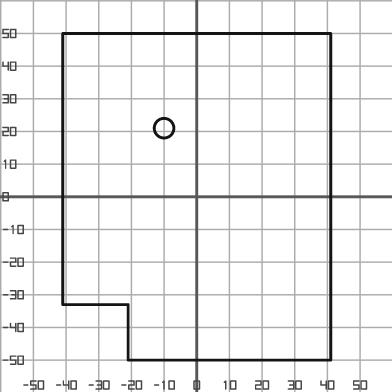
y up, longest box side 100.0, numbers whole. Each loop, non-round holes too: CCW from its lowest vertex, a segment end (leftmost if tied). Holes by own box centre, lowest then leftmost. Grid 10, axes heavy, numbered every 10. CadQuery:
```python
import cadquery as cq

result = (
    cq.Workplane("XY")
    .moveTo(-21.0, -50.0)
    .lineTo(41.0, -50.0)
    .lineTo(41.0, 50.0)
    .lineTo(-41.0, 50.0)
    .lineTo(-41.0, -33.0)
    .lineTo(-21.0, -33.0)
    .close()
    .moveTo(-10.0, 21.0)
    .circle(3.0)
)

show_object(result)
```